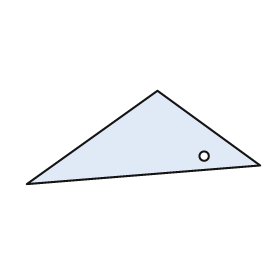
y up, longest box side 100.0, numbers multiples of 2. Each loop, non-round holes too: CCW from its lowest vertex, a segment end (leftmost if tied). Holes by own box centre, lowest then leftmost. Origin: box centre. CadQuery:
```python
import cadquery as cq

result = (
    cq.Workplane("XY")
    .moveTo(-50.0, -20.0)
    .lineTo(50.0, -12.0)
    .lineTo(6.0, 20.0)
    .close()
    .moveTo(26.0, -8.0)
    .circle(2.0)
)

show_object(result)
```